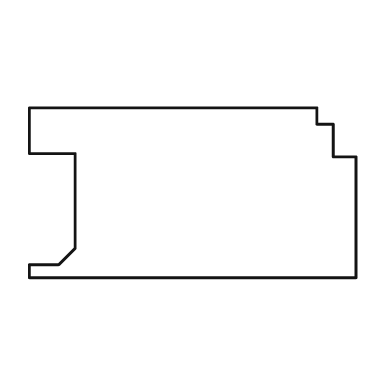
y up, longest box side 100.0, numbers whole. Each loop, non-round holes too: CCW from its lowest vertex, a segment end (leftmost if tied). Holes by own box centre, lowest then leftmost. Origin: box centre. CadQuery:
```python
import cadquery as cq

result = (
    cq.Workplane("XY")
    .moveTo(-50.0, -26.0)
    .lineTo(50.0, -26.0)
    .lineTo(50.0, 11.0)
    .lineTo(43.0, 11.0)
    .lineTo(43.0, 21.0)
    .lineTo(38.0, 21.0)
    .lineTo(38.0, 26.0)
    .lineTo(-50.0, 26.0)
    .lineTo(-50.0, 12.0)
    .lineTo(-36.0, 12.0)
    .lineTo(-36.0, -17.0)
    .lineTo(-41.0, -22.0)
    .lineTo(-50.0, -22.0)
    .close()
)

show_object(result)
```